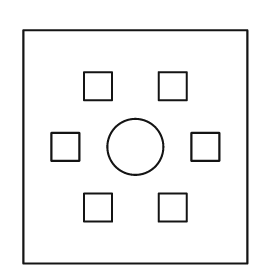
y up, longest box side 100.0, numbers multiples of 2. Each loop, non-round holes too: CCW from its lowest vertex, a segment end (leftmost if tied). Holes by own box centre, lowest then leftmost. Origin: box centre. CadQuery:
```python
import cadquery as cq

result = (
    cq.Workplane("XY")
    .moveTo(-48.0, -50.0)
    .lineTo(48.0, -50.0)
    .lineTo(48.0, 50.0)
    .lineTo(-48.0, 50.0)
    .close()
    .moveTo(-22.0, -32.0)
    .lineTo(-10.0, -32.0)
    .lineTo(-10.0, -20.0)
    .lineTo(-22.0, -20.0)
    .close()
    .moveTo(10.0, -32.0)
    .lineTo(22.0, -32.0)
    .lineTo(22.0, -20.0)
    .lineTo(10.0, -20.0)
    .close()
    .moveTo(-36.0, -6.0)
    .lineTo(-24.0, -6.0)
    .lineTo(-24.0, 6.0)
    .lineTo(-36.0, 6.0)
    .close()
    .moveTo(0.0, 0.0)
    .circle(12.0)
    .moveTo(24.0, -6.0)
    .lineTo(36.0, -6.0)
    .lineTo(36.0, 6.0)
    .lineTo(24.0, 6.0)
    .close()
    .moveTo(-22.0, 20.0)
    .lineTo(-10.0, 20.0)
    .lineTo(-10.0, 32.0)
    .lineTo(-22.0, 32.0)
    .close()
    .moveTo(10.0, 20.0)
    .lineTo(22.0, 20.0)
    .lineTo(22.0, 32.0)
    .lineTo(10.0, 32.0)
    .close()
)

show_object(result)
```